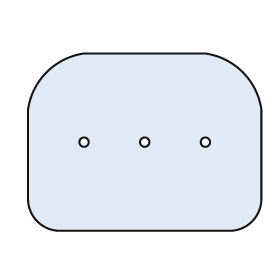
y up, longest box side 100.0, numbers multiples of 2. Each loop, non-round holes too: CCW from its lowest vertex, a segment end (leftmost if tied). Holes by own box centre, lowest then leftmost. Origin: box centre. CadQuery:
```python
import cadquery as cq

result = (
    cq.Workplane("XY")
    .moveTo(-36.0, -38.0)
    .lineTo(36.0, -38.0)
    .threePointArc((46.0, -34.0), (50.0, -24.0))
    .lineTo(50.0, 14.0)
    .threePointArc((42.0, 30.0), (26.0, 38.0))
    .lineTo(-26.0, 38.0)
    .threePointArc((-42.0, 30.0), (-50.0, 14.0))
    .lineTo(-50.0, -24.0)
    .threePointArc((-46.0, -34.0), (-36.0, -38.0))
    .close()
    .moveTo(-26.0, 0.0)
    .circle(2.0)
    .moveTo(0.0, 0.0)
    .circle(2.0)
    .moveTo(26.0, 0.0)
    .circle(2.0)
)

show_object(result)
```